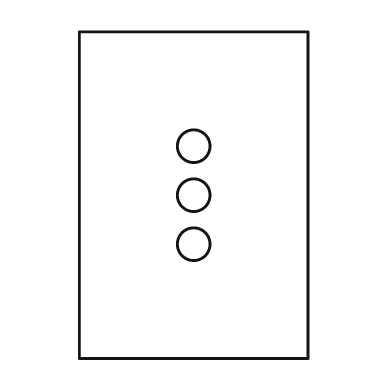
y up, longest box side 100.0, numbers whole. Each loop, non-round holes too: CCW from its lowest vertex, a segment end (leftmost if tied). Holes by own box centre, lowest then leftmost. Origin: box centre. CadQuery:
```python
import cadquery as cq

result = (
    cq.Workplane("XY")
    .moveTo(-35.0, -50.0)
    .lineTo(35.0, -50.0)
    .lineTo(35.0, 50.0)
    .lineTo(-35.0, 50.0)
    .close()
    .moveTo(0.0, -15.0)
    .circle(5.0)
    .moveTo(0.0, 0.0)
    .circle(5.0)
    .moveTo(0.0, 15.0)
    .circle(5.0)
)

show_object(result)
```